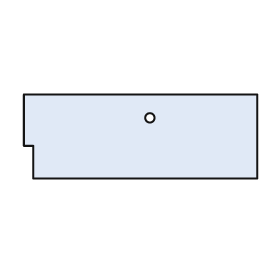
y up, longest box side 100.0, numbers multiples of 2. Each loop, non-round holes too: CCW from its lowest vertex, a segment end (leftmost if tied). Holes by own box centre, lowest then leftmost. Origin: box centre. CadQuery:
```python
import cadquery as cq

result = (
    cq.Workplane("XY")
    .moveTo(-46.0, -18.0)
    .lineTo(50.0, -18.0)
    .lineTo(50.0, 18.0)
    .lineTo(-50.0, 18.0)
    .lineTo(-50.0, -4.0)
    .lineTo(-46.0, -4.0)
    .close()
    .moveTo(4.0, 8.0)
    .circle(2.0)
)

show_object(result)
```